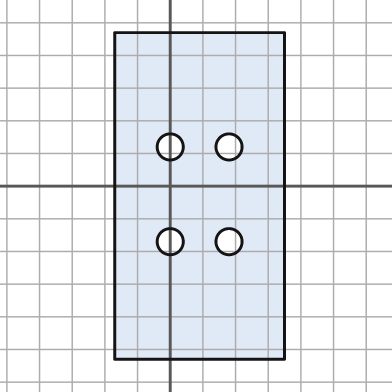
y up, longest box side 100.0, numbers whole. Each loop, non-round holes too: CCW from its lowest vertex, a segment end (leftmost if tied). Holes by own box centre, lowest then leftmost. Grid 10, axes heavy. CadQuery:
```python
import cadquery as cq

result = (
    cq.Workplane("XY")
    .moveTo(-17.0, -53.0)
    .lineTo(35.0, -53.0)
    .lineTo(35.0, 47.0)
    .lineTo(-17.0, 47.0)
    .close()
    .moveTo(0.0, -17.0)
    .circle(4.0)
    .moveTo(18.0, -17.0)
    .circle(4.0)
    .moveTo(0.0, 12.0)
    .circle(4.0)
    .moveTo(18.0, 12.0)
    .circle(4.0)
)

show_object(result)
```